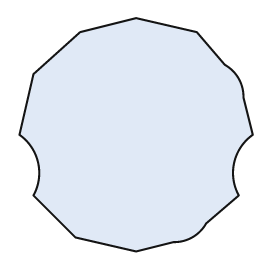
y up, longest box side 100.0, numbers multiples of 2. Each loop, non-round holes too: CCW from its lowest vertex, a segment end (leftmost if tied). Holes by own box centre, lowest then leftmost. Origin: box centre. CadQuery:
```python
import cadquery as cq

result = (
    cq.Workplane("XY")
    .moveTo(0.0, -50.0)
    .lineTo(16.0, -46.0)
    .threePointArc((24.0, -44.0), (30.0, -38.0))
    .lineTo(44.0, -26.0)
    .threePointArc((42.0, -12.0), (50.0, 0.0))
    .lineTo(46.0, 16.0)
    .threePointArc((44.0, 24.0), (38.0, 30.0))
    .lineTo(26.0, 44.0)
    .lineTo(0.0, 50.0)
    .lineTo(-24.0, 44.0)
    .lineTo(-44.0, 26.0)
    .lineTo(-50.0, 0.0)
    .threePointArc((-42.0, -12.0), (-44.0, -26.0))
    .lineTo(-26.0, -44.0)
    .close()
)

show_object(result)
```